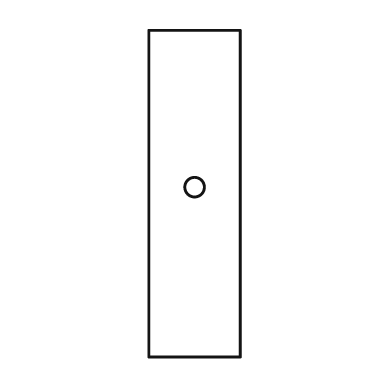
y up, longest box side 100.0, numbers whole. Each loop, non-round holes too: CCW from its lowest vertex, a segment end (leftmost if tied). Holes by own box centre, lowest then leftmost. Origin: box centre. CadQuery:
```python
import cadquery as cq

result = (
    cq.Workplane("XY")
    .moveTo(-14.0, -50.0)
    .lineTo(14.0, -50.0)
    .lineTo(14.0, 50.0)
    .lineTo(-14.0, 50.0)
    .close()
    .moveTo(0.0, 2.0)
    .circle(3.0)
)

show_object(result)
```